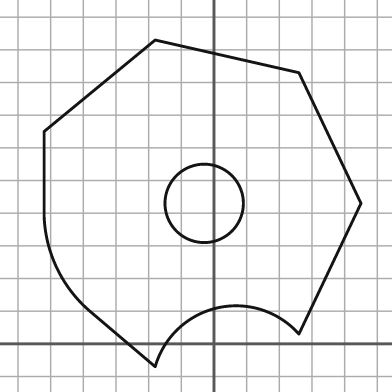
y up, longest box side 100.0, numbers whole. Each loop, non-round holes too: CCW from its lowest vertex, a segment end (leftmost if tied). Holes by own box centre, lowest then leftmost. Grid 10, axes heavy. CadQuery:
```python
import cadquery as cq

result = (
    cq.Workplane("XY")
    .moveTo(-18.0, -7.0)
    .threePointArc((1.0, 11.0), (26.0, 3.0))
    .lineTo(45.0, 43.0)
    .lineTo(26.0, 83.0)
    .lineTo(-18.0, 93.0)
    .lineTo(-52.0, 65.0)
    .lineTo(-52.0, 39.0)
    .threePointArc((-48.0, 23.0), (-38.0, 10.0))
    .close()
    .moveTo(-3.0, 43.0)
    .circle(12.0)
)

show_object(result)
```